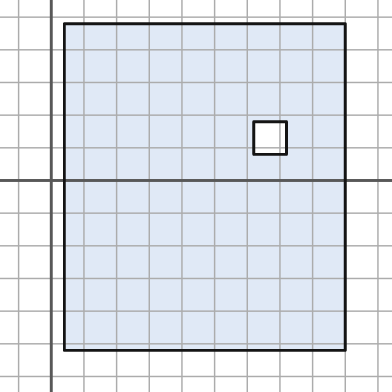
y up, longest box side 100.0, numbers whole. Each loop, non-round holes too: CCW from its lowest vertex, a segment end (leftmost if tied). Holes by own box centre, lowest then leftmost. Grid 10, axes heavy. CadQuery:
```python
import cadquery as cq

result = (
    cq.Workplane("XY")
    .moveTo(4.0, -52.0)
    .lineTo(90.0, -52.0)
    .lineTo(90.0, 48.0)
    .lineTo(4.0, 48.0)
    .close()
    .moveTo(62.0, 8.0)
    .lineTo(72.0, 8.0)
    .lineTo(72.0, 18.0)
    .lineTo(62.0, 18.0)
    .close()
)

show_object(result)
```